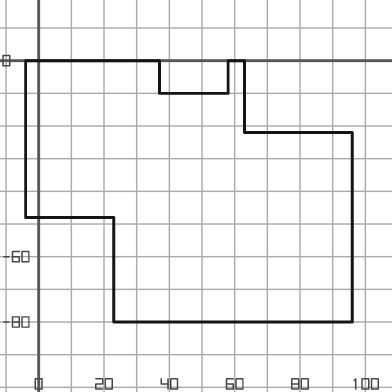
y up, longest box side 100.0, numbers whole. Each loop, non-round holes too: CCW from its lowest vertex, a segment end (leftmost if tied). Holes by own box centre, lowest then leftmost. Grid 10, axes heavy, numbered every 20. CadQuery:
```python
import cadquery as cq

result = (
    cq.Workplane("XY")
    .moveTo(23.0, -80.0)
    .lineTo(96.0, -80.0)
    .lineTo(96.0, -22.0)
    .lineTo(63.0, -22.0)
    .lineTo(63.0, 0.0)
    .lineTo(58.0, 0.0)
    .lineTo(58.0, -10.0)
    .lineTo(37.0, -10.0)
    .lineTo(37.0, 0.0)
    .lineTo(-4.0, 0.0)
    .lineTo(-4.0, -48.0)
    .lineTo(23.0, -48.0)
    .close()
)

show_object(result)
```